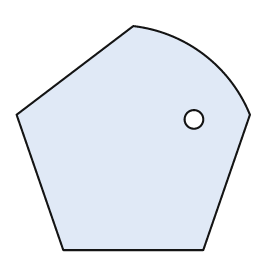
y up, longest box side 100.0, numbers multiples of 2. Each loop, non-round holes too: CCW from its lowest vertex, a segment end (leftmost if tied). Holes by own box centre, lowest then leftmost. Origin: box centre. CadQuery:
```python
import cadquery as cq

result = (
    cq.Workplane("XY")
    .moveTo(-30.0, -48.0)
    .lineTo(30.0, -48.0)
    .lineTo(50.0, 10.0)
    .threePointArc((30.0, 36.0), (0.0, 48.0))
    .lineTo(-50.0, 10.0)
    .close()
    .moveTo(26.0, 8.0)
    .circle(4.0)
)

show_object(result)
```